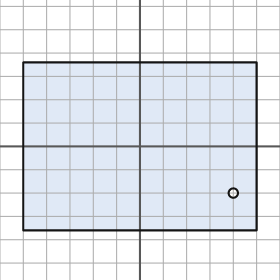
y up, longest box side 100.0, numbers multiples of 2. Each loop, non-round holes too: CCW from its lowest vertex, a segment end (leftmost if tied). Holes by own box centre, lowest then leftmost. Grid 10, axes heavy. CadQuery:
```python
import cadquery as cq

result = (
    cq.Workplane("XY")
    .moveTo(-50.0, -36.0)
    .lineTo(50.0, -36.0)
    .lineTo(50.0, 36.0)
    .lineTo(-50.0, 36.0)
    .close()
    .moveTo(40.0, -20.0)
    .circle(2.0)
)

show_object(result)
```